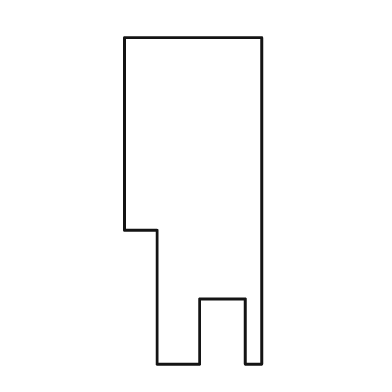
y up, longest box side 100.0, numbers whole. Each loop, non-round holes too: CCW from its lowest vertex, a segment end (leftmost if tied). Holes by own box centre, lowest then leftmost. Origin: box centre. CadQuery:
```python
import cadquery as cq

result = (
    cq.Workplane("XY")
    .moveTo(-11.0, -50.0)
    .lineTo(2.0, -50.0)
    .lineTo(2.0, -30.0)
    .lineTo(16.0, -30.0)
    .lineTo(16.0, -50.0)
    .lineTo(21.0, -50.0)
    .lineTo(21.0, 50.0)
    .lineTo(-21.0, 50.0)
    .lineTo(-21.0, -9.0)
    .lineTo(-11.0, -9.0)
    .close()
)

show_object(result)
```